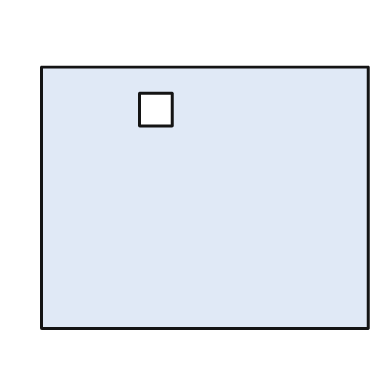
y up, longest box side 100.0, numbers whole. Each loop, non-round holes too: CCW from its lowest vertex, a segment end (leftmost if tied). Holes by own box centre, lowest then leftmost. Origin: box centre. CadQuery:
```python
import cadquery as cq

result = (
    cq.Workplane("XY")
    .moveTo(-50.0, -40.0)
    .lineTo(50.0, -40.0)
    .lineTo(50.0, 40.0)
    .lineTo(-50.0, 40.0)
    .close()
    .moveTo(-20.0, 22.0)
    .lineTo(-10.0, 22.0)
    .lineTo(-10.0, 32.0)
    .lineTo(-20.0, 32.0)
    .close()
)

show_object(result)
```